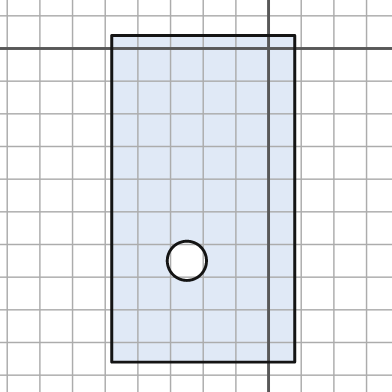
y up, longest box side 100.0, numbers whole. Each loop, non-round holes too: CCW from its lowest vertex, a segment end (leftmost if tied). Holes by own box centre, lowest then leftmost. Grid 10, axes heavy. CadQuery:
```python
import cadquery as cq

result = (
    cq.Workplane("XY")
    .moveTo(-48.0, -96.0)
    .lineTo(8.0, -96.0)
    .lineTo(8.0, 4.0)
    .lineTo(-48.0, 4.0)
    .close()
    .moveTo(-25.0, -65.0)
    .circle(6.0)
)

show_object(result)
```